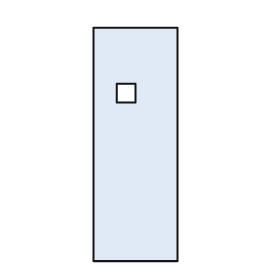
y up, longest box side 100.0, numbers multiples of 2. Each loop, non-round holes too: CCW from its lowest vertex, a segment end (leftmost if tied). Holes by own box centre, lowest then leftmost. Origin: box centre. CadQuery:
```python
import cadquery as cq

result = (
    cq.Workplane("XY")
    .moveTo(-18.0, -50.0)
    .lineTo(18.0, -50.0)
    .lineTo(18.0, 50.0)
    .lineTo(-18.0, 50.0)
    .close()
    .moveTo(-8.0, 18.0)
    .lineTo(0.0, 18.0)
    .lineTo(0.0, 26.0)
    .lineTo(-8.0, 26.0)
    .close()
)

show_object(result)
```